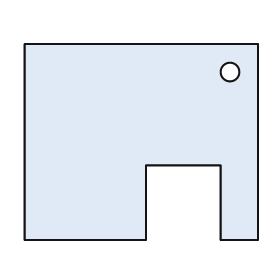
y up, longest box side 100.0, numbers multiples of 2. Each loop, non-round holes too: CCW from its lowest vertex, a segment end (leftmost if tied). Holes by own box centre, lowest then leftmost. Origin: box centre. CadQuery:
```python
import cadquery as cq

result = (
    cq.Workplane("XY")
    .moveTo(-50.0, -42.0)
    .lineTo(2.0, -42.0)
    .lineTo(2.0, -10.0)
    .lineTo(34.0, -10.0)
    .lineTo(34.0, -42.0)
    .lineTo(50.0, -42.0)
    .lineTo(50.0, 42.0)
    .lineTo(-50.0, 42.0)
    .close()
    .moveTo(38.0, 30.0)
    .circle(4.0)
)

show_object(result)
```